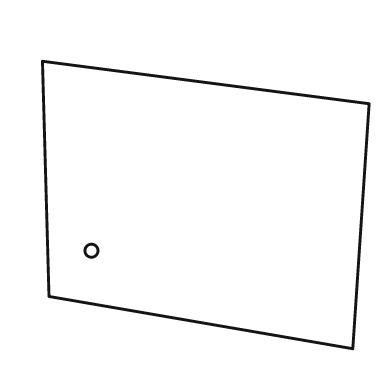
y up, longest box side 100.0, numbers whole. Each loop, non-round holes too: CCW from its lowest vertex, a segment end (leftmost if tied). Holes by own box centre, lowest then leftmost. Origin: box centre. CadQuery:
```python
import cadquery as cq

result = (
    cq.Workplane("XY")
    .moveTo(45.0, -44.0)
    .lineTo(50.0, 31.0)
    .lineTo(-50.0, 44.0)
    .lineTo(-48.0, -28.0)
    .close()
    .moveTo(-35.0, -14.0)
    .circle(2.0)
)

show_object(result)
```